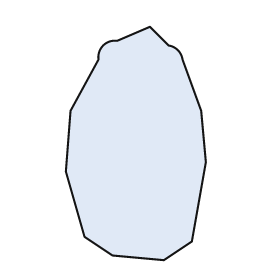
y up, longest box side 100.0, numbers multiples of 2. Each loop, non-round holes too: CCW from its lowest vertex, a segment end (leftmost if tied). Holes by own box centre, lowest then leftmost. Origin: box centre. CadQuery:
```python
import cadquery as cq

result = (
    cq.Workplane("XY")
    .moveTo(12.0, -50.0)
    .lineTo(24.0, -42.0)
    .lineTo(30.0, -8.0)
    .lineTo(28.0, 14.0)
    .lineTo(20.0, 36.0)
    .threePointArc((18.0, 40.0), (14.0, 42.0))
    .lineTo(6.0, 50.0)
    .lineTo(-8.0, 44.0)
    .threePointArc((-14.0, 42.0), (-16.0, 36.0))
    .lineTo(-28.0, 14.0)
    .lineTo(-30.0, -12.0)
    .lineTo(-22.0, -40.0)
    .lineTo(-10.0, -48.0)
    .close()
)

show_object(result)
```